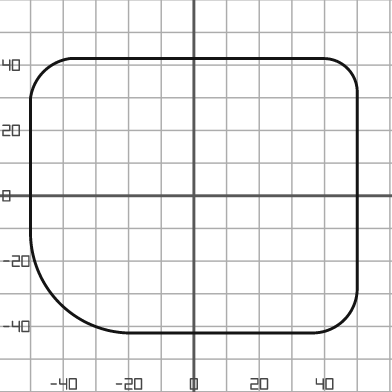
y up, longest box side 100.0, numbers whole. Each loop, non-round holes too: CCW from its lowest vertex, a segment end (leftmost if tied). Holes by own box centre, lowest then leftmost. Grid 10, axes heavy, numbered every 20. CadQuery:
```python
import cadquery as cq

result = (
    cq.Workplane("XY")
    .moveTo(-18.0, -42.0)
    .lineTo(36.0, -42.0)
    .threePointArc((46.0, -38.0), (50.0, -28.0))
    .lineTo(50.0, 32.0)
    .threePointArc((47.0, 39.0), (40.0, 42.0))
    .lineTo(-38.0, 42.0)
    .threePointArc((-46.0, 38.0), (-50.0, 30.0))
    .lineTo(-50.0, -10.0)
    .threePointArc((-41.0, -33.0), (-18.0, -42.0))
    .close()
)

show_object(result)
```